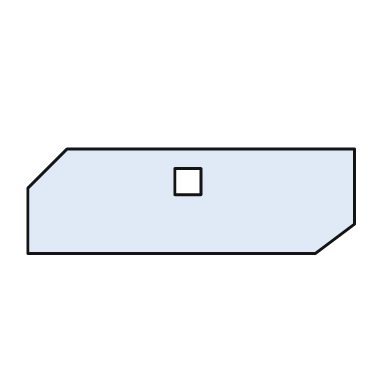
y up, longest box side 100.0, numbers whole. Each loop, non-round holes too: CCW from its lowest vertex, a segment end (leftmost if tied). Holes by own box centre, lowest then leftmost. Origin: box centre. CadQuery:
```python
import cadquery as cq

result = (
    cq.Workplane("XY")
    .moveTo(-50.0, -16.0)
    .lineTo(38.0, -16.0)
    .lineTo(50.0, -7.0)
    .lineTo(50.0, 16.0)
    .lineTo(-38.0, 16.0)
    .lineTo(-50.0, 4.0)
    .close()
    .moveTo(-5.0, 2.0)
    .lineTo(3.0, 2.0)
    .lineTo(3.0, 10.0)
    .lineTo(-5.0, 10.0)
    .close()
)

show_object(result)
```